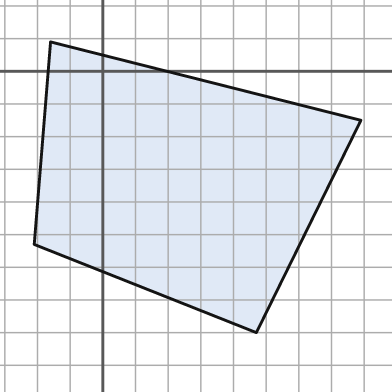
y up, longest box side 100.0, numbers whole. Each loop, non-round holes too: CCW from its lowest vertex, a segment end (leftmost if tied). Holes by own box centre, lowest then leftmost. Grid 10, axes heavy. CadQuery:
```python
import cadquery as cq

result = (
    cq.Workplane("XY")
    .moveTo(47.0, -80.0)
    .lineTo(79.0, -15.0)
    .lineTo(-16.0, 9.0)
    .lineTo(-21.0, -53.0)
    .close()
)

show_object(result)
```